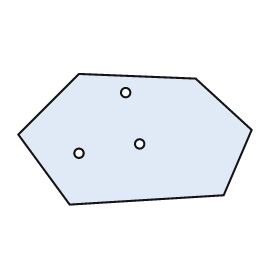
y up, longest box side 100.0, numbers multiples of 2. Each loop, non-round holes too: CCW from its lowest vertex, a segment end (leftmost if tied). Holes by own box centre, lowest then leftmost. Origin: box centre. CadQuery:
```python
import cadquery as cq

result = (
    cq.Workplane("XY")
    .moveTo(-28.0, -28.0)
    .lineTo(38.0, -24.0)
    .lineTo(50.0, 4.0)
    .lineTo(26.0, 26.0)
    .lineTo(-24.0, 28.0)
    .lineTo(-50.0, 2.0)
    .close()
    .moveTo(-24.0, -6.0)
    .circle(2.0)
    .moveTo(2.0, -2.0)
    .circle(2.0)
    .moveTo(-4.0, 20.0)
    .circle(2.0)
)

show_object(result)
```